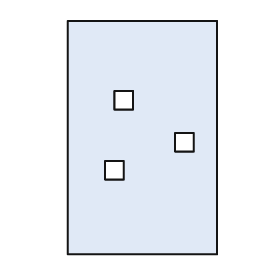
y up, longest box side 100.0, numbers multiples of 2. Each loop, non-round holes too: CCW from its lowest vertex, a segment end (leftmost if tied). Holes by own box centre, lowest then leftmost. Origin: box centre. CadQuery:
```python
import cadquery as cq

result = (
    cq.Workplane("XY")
    .moveTo(-32.0, -50.0)
    .lineTo(32.0, -50.0)
    .lineTo(32.0, 50.0)
    .lineTo(-32.0, 50.0)
    .close()
    .moveTo(-16.0, -18.0)
    .lineTo(-8.0, -18.0)
    .lineTo(-8.0, -10.0)
    .lineTo(-16.0, -10.0)
    .close()
    .moveTo(14.0, -6.0)
    .lineTo(22.0, -6.0)
    .lineTo(22.0, 2.0)
    .lineTo(14.0, 2.0)
    .close()
    .moveTo(-12.0, 12.0)
    .lineTo(-4.0, 12.0)
    .lineTo(-4.0, 20.0)
    .lineTo(-12.0, 20.0)
    .close()
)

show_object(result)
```